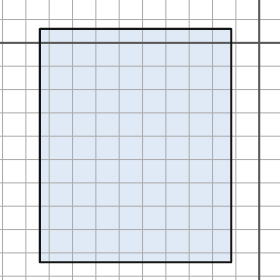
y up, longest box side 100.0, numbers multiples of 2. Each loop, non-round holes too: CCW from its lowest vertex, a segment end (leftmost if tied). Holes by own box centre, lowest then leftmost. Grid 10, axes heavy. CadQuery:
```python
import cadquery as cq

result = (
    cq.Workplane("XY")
    .moveTo(-94.0, -94.0)
    .lineTo(-12.0, -94.0)
    .lineTo(-12.0, 6.0)
    .lineTo(-94.0, 6.0)
    .close()
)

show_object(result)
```